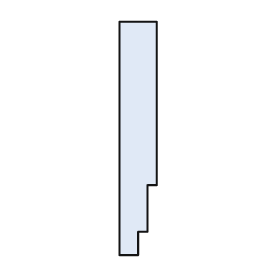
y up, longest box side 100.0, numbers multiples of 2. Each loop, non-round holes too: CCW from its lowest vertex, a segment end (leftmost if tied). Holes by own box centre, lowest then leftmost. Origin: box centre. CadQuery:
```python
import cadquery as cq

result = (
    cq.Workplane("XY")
    .moveTo(-8.0, -50.0)
    .lineTo(0.0, -50.0)
    .lineTo(0.0, -40.0)
    .lineTo(4.0, -40.0)
    .lineTo(4.0, -20.0)
    .lineTo(8.0, -20.0)
    .lineTo(8.0, 50.0)
    .lineTo(-8.0, 50.0)
    .close()
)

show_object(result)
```